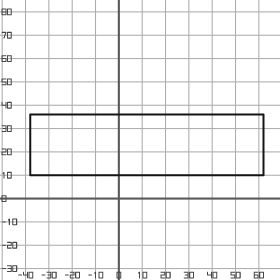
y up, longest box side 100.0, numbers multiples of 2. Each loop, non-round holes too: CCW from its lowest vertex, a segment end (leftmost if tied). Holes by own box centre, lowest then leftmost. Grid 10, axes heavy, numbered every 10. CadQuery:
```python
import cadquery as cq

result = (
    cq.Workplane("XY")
    .moveTo(-38.0, 10.0)
    .lineTo(62.0, 10.0)
    .lineTo(62.0, 36.0)
    .lineTo(-38.0, 36.0)
    .close()
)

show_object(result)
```